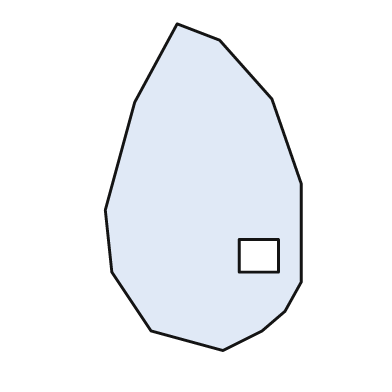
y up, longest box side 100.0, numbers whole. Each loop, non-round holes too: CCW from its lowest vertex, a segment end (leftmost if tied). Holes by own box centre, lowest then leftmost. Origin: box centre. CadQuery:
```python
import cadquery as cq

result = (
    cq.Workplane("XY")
    .moveTo(6.0, -50.0)
    .lineTo(18.0, -44.0)
    .lineTo(25.0, -38.0)
    .lineTo(30.0, -29.0)
    .lineTo(30.0, 1.0)
    .lineTo(21.0, 27.0)
    .lineTo(5.0, 45.0)
    .lineTo(-8.0, 50.0)
    .lineTo(-21.0, 26.0)
    .lineTo(-30.0, -7.0)
    .lineTo(-28.0, -26.0)
    .lineTo(-16.0, -44.0)
    .close()
    .moveTo(11.0, -26.0)
    .lineTo(23.0, -26.0)
    .lineTo(23.0, -16.0)
    .lineTo(11.0, -16.0)
    .close()
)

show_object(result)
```